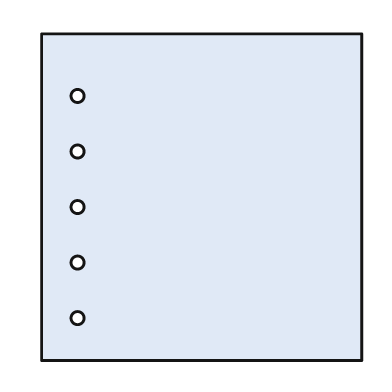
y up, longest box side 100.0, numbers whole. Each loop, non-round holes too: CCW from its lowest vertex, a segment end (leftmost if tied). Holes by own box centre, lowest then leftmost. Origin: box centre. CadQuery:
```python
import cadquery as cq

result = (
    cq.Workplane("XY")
    .moveTo(-49.0, -50.0)
    .lineTo(49.0, -50.0)
    .lineTo(49.0, 50.0)
    .lineTo(-49.0, 50.0)
    .close()
    .moveTo(-38.0, -37.0)
    .circle(2.0)
    .moveTo(-38.0, -20.0)
    .circle(2.0)
    .moveTo(-38.0, -3.0)
    .circle(2.0)
    .moveTo(-38.0, 14.0)
    .circle(2.0)
    .moveTo(-38.0, 31.0)
    .circle(2.0)
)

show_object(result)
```